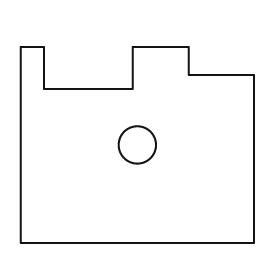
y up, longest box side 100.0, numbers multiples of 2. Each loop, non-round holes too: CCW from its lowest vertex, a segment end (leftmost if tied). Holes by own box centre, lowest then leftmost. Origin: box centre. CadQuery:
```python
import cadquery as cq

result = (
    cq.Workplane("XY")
    .moveTo(-50.0, -42.0)
    .lineTo(50.0, -42.0)
    .lineTo(50.0, 30.0)
    .lineTo(22.0, 30.0)
    .lineTo(22.0, 42.0)
    .lineTo(-2.0, 42.0)
    .lineTo(-2.0, 24.0)
    .lineTo(-40.0, 24.0)
    .lineTo(-40.0, 42.0)
    .lineTo(-50.0, 42.0)
    .close()
    .moveTo(0.0, 0.0)
    .circle(8.0)
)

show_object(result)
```